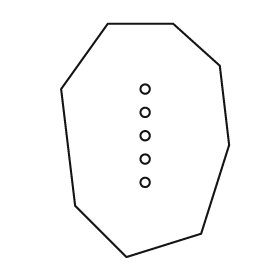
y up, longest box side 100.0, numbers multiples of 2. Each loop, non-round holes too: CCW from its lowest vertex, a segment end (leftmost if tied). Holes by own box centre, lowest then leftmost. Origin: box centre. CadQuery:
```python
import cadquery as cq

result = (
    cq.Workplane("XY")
    .moveTo(-8.0, -50.0)
    .lineTo(24.0, -40.0)
    .lineTo(36.0, -2.0)
    .lineTo(32.0, 32.0)
    .lineTo(12.0, 50.0)
    .lineTo(-16.0, 50.0)
    .lineTo(-36.0, 22.0)
    .lineTo(-30.0, -28.0)
    .close()
    .moveTo(0.0, -18.0)
    .circle(2.0)
    .moveTo(0.0, -8.0)
    .circle(2.0)
    .moveTo(0.0, 2.0)
    .circle(2.0)
    .moveTo(0.0, 12.0)
    .circle(2.0)
    .moveTo(0.0, 22.0)
    .circle(2.0)
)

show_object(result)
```